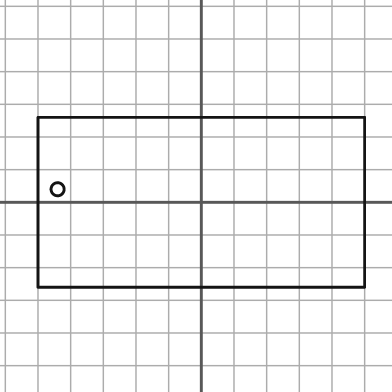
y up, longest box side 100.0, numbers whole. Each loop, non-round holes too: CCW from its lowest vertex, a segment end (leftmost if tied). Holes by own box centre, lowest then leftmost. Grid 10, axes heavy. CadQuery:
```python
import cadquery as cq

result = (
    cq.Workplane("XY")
    .moveTo(-50.0, -26.0)
    .lineTo(50.0, -26.0)
    .lineTo(50.0, 26.0)
    .lineTo(-50.0, 26.0)
    .close()
    .moveTo(-44.0, 4.0)
    .circle(2.0)
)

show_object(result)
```